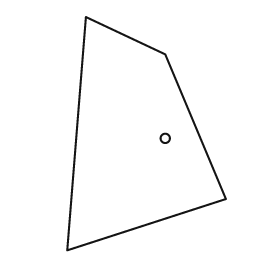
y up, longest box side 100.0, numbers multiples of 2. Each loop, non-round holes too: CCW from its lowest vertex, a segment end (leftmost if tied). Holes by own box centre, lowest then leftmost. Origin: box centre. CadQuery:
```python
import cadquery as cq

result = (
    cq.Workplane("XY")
    .moveTo(-34.0, -50.0)
    .lineTo(34.0, -28.0)
    .lineTo(8.0, 34.0)
    .lineTo(-26.0, 50.0)
    .close()
    .moveTo(8.0, -2.0)
    .circle(2.0)
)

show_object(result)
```